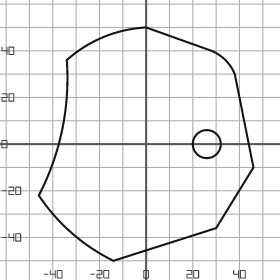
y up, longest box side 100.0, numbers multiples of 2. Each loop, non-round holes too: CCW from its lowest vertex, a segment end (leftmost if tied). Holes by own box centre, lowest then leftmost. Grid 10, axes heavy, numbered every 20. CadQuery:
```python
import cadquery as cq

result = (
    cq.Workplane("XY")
    .moveTo(-14.0, -50.0)
    .lineTo(30.0, -36.0)
    .lineTo(46.0, -10.0)
    .lineTo(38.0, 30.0)
    .threePointArc((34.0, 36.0), (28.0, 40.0))
    .lineTo(0.0, 50.0)
    .threePointArc((-18.0, 46.0), (-34.0, 36.0))
    .threePointArc((-36.0, 6.0), (-46.0, -22.0))
    .threePointArc((-32.0, -38.0), (-14.0, -50.0))
    .close()
    .moveTo(26.0, 0.0)
    .circle(6.0)
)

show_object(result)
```